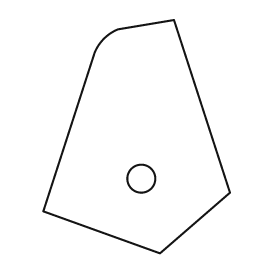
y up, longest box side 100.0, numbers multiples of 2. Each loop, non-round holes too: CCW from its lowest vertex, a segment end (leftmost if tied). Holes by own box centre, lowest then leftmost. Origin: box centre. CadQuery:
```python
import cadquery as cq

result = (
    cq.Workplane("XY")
    .moveTo(10.0, -50.0)
    .lineTo(40.0, -24.0)
    .lineTo(16.0, 50.0)
    .lineTo(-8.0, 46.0)
    .threePointArc((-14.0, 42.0), (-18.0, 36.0))
    .lineTo(-40.0, -32.0)
    .close()
    .moveTo(2.0, -18.0)
    .circle(6.0)
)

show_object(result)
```